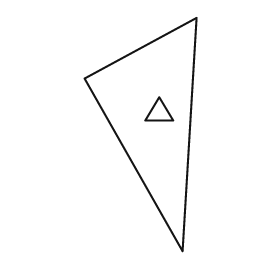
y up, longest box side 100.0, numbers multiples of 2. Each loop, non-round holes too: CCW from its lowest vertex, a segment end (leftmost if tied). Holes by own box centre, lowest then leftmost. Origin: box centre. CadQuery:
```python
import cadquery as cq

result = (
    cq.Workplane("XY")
    .moveTo(18.0, -50.0)
    .lineTo(24.0, 50.0)
    .lineTo(-24.0, 24.0)
    .close()
    .moveTo(2.0, 6.0)
    .lineTo(14.0, 6.0)
    .lineTo(8.0, 16.0)
    .close()
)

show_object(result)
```